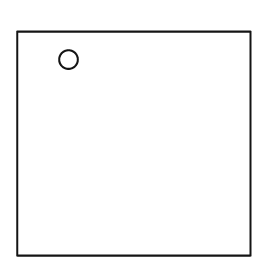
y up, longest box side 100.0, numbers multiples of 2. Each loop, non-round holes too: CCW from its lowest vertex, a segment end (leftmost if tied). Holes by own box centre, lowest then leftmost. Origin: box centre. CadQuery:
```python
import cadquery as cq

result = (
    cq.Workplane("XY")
    .moveTo(-50.0, -48.0)
    .lineTo(50.0, -48.0)
    .lineTo(50.0, 48.0)
    .lineTo(-50.0, 48.0)
    .close()
    .moveTo(-28.0, 36.0)
    .circle(4.0)
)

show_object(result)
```